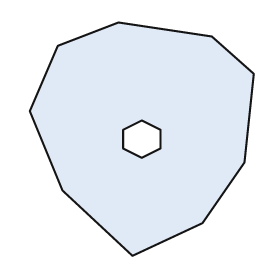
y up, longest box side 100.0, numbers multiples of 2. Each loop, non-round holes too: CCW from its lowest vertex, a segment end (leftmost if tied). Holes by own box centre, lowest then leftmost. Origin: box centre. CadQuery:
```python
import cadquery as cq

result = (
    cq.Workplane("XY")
    .moveTo(-4.0, -50.0)
    .lineTo(26.0, -36.0)
    .lineTo(44.0, -10.0)
    .lineTo(48.0, 28.0)
    .lineTo(30.0, 44.0)
    .lineTo(-10.0, 50.0)
    .lineTo(-36.0, 40.0)
    .lineTo(-48.0, 12.0)
    .lineTo(-34.0, -22.0)
    .close()
    .moveTo(0.0, -8.0)
    .lineTo(8.0, -4.0)
    .lineTo(8.0, 4.0)
    .lineTo(0.0, 8.0)
    .lineTo(-8.0, 4.0)
    .lineTo(-8.0, -4.0)
    .close()
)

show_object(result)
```